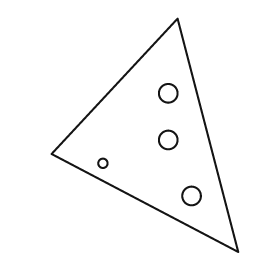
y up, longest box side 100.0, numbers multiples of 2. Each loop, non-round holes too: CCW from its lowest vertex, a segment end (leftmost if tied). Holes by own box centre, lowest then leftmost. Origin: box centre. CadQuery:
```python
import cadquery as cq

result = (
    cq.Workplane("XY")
    .moveTo(40.0, -50.0)
    .lineTo(14.0, 50.0)
    .lineTo(-40.0, -8.0)
    .close()
    .moveTo(20.0, -26.0)
    .circle(4.0)
    .moveTo(-18.0, -12.0)
    .circle(2.0)
    .moveTo(10.0, -2.0)
    .circle(4.0)
    .moveTo(10.0, 18.0)
    .circle(4.0)
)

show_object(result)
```